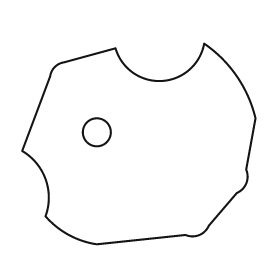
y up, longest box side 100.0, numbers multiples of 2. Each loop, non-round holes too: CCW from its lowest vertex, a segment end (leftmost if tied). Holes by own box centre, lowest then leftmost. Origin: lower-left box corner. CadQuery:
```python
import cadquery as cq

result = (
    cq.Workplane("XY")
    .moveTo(32.0, 0.0)
    .lineTo(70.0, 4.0)
    .threePointArc((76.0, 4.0), (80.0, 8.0))
    .lineTo(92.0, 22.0)
    .threePointArc((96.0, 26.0), (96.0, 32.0))
    .lineTo(100.0, 54.0)
    .threePointArc((92.0, 72.0), (78.0, 86.0))
    .threePointArc((60.0, 70.0), (40.0, 84.0))
    .lineTo(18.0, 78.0)
    .threePointArc((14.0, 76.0), (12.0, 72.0))
    .lineTo(0.0, 40.0)
    .threePointArc((10.0, 28.0), (10.0, 12.0))
    .threePointArc((20.0, 4.0), (32.0, 0.0))
    .close()
    .moveTo(32.0, 48.0)
    .circle(6.0)
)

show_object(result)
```